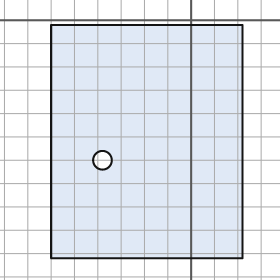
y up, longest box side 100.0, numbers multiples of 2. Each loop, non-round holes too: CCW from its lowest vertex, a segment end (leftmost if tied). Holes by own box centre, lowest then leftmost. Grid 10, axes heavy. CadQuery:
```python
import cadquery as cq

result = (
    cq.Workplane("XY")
    .moveTo(-60.0, -102.0)
    .lineTo(22.0, -102.0)
    .lineTo(22.0, -2.0)
    .lineTo(-60.0, -2.0)
    .close()
    .moveTo(-38.0, -60.0)
    .circle(4.0)
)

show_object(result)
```